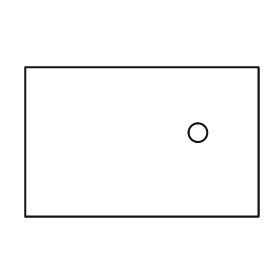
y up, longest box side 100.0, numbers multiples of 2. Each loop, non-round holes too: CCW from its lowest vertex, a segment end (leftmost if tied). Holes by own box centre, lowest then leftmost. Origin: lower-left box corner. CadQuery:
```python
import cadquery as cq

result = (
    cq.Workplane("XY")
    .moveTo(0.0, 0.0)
    .lineTo(100.0, 0.0)
    .lineTo(100.0, 64.0)
    .lineTo(0.0, 64.0)
    .close()
    .moveTo(74.0, 36.0)
    .circle(4.0)
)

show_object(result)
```